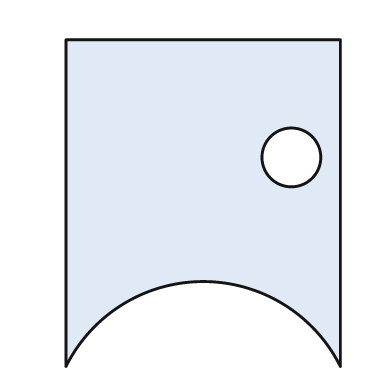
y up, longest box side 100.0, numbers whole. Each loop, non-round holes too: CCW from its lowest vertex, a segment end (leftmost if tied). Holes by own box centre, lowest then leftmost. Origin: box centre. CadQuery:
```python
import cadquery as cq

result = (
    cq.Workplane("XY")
    .moveTo(-42.0, -50.0)
    .threePointArc((0.0, -24.0), (42.0, -50.0))
    .lineTo(42.0, 50.0)
    .lineTo(-42.0, 50.0)
    .close()
    .moveTo(27.0, 14.0)
    .circle(9.0)
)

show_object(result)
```